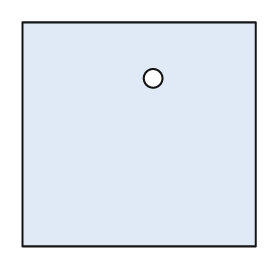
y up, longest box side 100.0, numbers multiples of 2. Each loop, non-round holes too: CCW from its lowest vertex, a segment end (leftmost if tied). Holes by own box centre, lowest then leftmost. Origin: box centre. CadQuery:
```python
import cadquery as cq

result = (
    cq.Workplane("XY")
    .moveTo(-50.0, -48.0)
    .lineTo(50.0, -48.0)
    .lineTo(50.0, 48.0)
    .lineTo(-50.0, 48.0)
    .close()
    .moveTo(6.0, 24.0)
    .circle(4.0)
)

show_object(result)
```